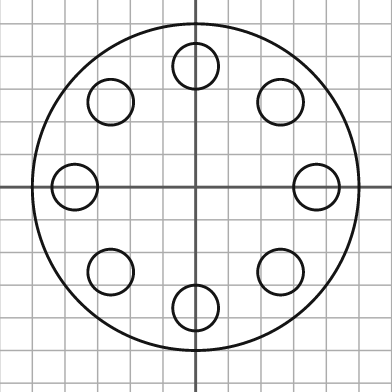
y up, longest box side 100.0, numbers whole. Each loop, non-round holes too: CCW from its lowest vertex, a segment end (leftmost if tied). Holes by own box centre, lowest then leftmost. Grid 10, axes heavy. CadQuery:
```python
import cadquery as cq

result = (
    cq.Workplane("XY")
    .moveTo(0.0, 0.0)
    .circle(50.0)
    .moveTo(0.0, -37.0)
    .circle(7.0)
    .moveTo(-26.0, -26.0)
    .circle(7.0)
    .moveTo(26.0, -26.0)
    .circle(7.0)
    .moveTo(-37.0, 0.0)
    .circle(7.0)
    .moveTo(37.0, 0.0)
    .circle(7.0)
    .moveTo(-26.0, 26.0)
    .circle(7.0)
    .moveTo(26.0, 26.0)
    .circle(7.0)
    .moveTo(0.0, 37.0)
    .circle(7.0)
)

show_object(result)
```